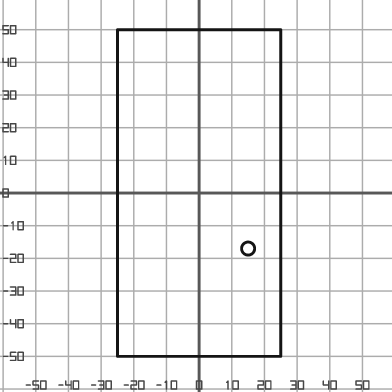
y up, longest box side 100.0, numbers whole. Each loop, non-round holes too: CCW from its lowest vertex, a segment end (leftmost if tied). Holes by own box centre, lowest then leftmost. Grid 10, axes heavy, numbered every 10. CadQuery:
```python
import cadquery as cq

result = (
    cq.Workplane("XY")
    .moveTo(-25.0, -50.0)
    .lineTo(25.0, -50.0)
    .lineTo(25.0, 50.0)
    .lineTo(-25.0, 50.0)
    .close()
    .moveTo(15.0, -17.0)
    .circle(2.0)
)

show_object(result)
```